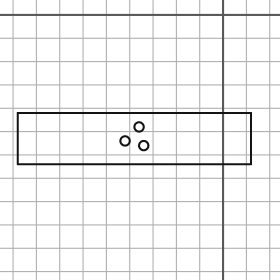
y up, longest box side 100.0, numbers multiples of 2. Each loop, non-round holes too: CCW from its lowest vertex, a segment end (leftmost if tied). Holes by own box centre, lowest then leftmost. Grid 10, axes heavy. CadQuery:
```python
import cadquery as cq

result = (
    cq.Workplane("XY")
    .moveTo(-88.0, -64.0)
    .lineTo(12.0, -64.0)
    .lineTo(12.0, -42.0)
    .lineTo(-88.0, -42.0)
    .close()
    .moveTo(-34.0, -56.0)
    .circle(2.0)
    .moveTo(-42.0, -54.0)
    .circle(2.0)
    .moveTo(-36.0, -48.0)
    .circle(2.0)
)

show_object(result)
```